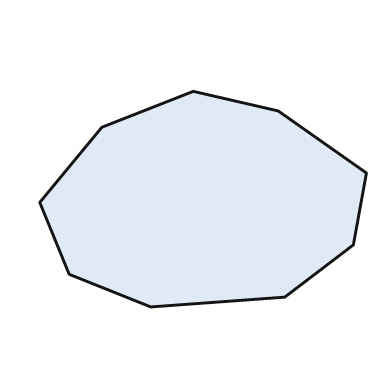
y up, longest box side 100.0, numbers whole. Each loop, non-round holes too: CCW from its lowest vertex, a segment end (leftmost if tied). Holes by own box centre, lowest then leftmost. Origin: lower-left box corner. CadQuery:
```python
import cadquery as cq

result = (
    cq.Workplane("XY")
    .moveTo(34.0, 0.0)
    .lineTo(75.0, 3.0)
    .lineTo(96.0, 19.0)
    .lineTo(100.0, 41.0)
    .lineTo(73.0, 60.0)
    .lineTo(47.0, 66.0)
    .lineTo(19.0, 55.0)
    .lineTo(0.0, 32.0)
    .lineTo(9.0, 10.0)
    .close()
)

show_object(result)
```